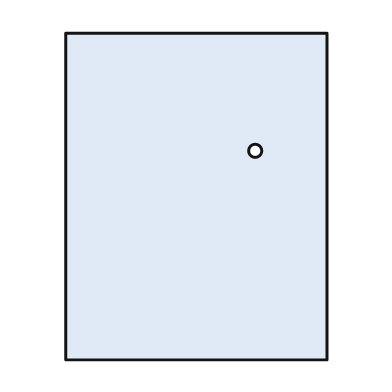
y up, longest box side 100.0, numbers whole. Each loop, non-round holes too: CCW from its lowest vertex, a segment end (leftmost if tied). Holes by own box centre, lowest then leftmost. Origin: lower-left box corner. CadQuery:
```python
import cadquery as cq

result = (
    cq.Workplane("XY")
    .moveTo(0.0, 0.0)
    .lineTo(80.0, 0.0)
    .lineTo(80.0, 100.0)
    .lineTo(0.0, 100.0)
    .close()
    .moveTo(58.0, 64.0)
    .circle(2.0)
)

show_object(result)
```